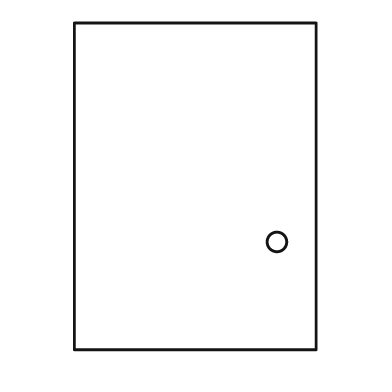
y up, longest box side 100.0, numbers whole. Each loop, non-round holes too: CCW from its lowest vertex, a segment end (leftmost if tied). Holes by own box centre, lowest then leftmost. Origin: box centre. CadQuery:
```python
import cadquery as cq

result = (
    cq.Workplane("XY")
    .moveTo(-37.0, -50.0)
    .lineTo(37.0, -50.0)
    .lineTo(37.0, 50.0)
    .lineTo(-37.0, 50.0)
    .close()
    .moveTo(25.0, -17.0)
    .circle(3.0)
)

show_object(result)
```